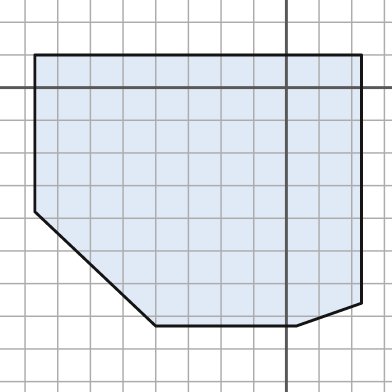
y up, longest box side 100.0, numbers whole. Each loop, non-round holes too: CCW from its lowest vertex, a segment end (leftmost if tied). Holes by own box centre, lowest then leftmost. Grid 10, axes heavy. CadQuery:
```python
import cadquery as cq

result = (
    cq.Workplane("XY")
    .moveTo(-40.0, -73.0)
    .lineTo(3.0, -73.0)
    .lineTo(23.0, -66.0)
    .lineTo(23.0, 10.0)
    .lineTo(-77.0, 10.0)
    .lineTo(-77.0, -38.0)
    .close()
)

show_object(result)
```